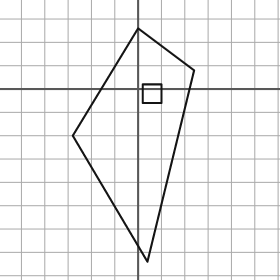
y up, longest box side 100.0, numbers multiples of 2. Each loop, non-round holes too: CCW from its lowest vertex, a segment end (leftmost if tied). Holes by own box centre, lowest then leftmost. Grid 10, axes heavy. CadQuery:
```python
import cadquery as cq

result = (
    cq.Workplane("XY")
    .moveTo(4.0, -74.0)
    .lineTo(24.0, 8.0)
    .lineTo(0.0, 26.0)
    .lineTo(-28.0, -20.0)
    .close()
    .moveTo(2.0, -6.0)
    .lineTo(10.0, -6.0)
    .lineTo(10.0, 2.0)
    .lineTo(2.0, 2.0)
    .close()
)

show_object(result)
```